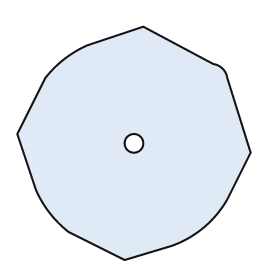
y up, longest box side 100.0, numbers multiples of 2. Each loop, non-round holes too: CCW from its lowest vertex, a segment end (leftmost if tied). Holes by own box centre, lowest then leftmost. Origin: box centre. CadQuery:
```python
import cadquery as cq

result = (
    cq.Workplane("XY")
    .moveTo(-4.0, -50.0)
    .lineTo(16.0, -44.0)
    .threePointArc((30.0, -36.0), (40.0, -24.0))
    .lineTo(50.0, -4.0)
    .lineTo(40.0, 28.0)
    .threePointArc((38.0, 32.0), (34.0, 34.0))
    .lineTo(4.0, 50.0)
    .lineTo(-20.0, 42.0)
    .threePointArc((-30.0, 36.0), (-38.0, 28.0))
    .lineTo(-50.0, 4.0)
    .lineTo(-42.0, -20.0)
    .threePointArc((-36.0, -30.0), (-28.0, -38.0))
    .close()
    .moveTo(0.0, 0.0)
    .circle(4.0)
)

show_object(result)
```